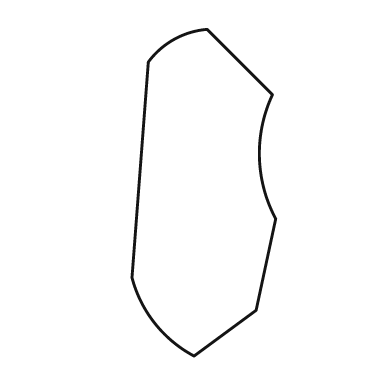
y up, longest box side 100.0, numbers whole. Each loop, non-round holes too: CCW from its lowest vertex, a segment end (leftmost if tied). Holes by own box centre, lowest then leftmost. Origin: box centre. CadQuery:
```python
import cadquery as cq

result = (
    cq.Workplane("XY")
    .moveTo(-3.0, -50.0)
    .lineTo(16.0, -36.0)
    .lineTo(22.0, -8.0)
    .threePointArc((17.0, 11.0), (21.0, 30.0))
    .lineTo(1.0, 50.0)
    .threePointArc((-9.0, 47.0), (-17.0, 40.0))
    .lineTo(-22.0, -26.0)
    .threePointArc((-15.0, -40.0), (-3.0, -50.0))
    .close()
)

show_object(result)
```